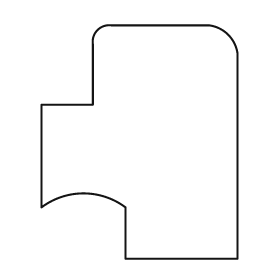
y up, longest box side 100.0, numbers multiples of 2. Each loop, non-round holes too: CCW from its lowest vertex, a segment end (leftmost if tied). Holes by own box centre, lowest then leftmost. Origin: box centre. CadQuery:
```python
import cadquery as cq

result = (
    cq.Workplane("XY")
    .moveTo(-6.0, -50.0)
    .lineTo(42.0, -50.0)
    .lineTo(42.0, 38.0)
    .threePointArc((38.0, 46.0), (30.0, 50.0))
    .lineTo(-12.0, 50.0)
    .threePointArc((-18.0, 48.0), (-20.0, 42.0))
    .lineTo(-20.0, 16.0)
    .lineTo(-42.0, 16.0)
    .lineTo(-42.0, -28.0)
    .threePointArc((-24.0, -22.0), (-6.0, -28.0))
    .close()
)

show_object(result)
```